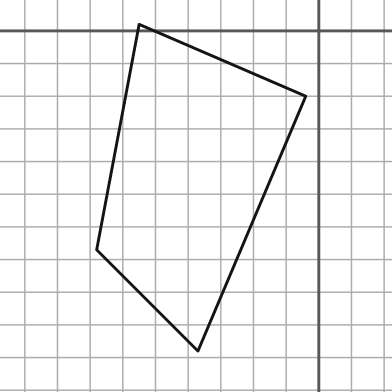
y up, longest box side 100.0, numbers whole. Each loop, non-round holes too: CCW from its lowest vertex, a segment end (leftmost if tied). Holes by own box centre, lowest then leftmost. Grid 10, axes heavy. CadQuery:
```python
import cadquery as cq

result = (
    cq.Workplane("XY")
    .moveTo(-37.0, -98.0)
    .lineTo(-4.0, -20.0)
    .lineTo(-55.0, 2.0)
    .lineTo(-68.0, -67.0)
    .close()
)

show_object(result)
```